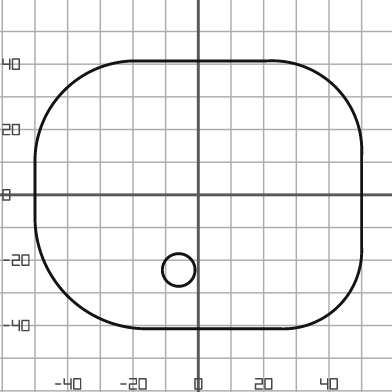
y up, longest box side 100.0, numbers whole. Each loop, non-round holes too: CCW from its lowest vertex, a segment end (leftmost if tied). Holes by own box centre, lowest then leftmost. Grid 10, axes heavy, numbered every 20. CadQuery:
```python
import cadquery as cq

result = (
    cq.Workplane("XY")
    .moveTo(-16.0, -41.0)
    .lineTo(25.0, -41.0)
    .threePointArc((43.0, -34.0), (50.0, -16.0))
    .lineTo(50.0, 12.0)
    .threePointArc((42.0, 33.0), (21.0, 41.0))
    .lineTo(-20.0, 41.0)
    .threePointArc((-41.0, 32.0), (-50.0, 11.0))
    .lineTo(-50.0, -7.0)
    .threePointArc((-40.0, -31.0), (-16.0, -41.0))
    .close()
    .moveTo(-6.0, -23.0)
    .circle(5.0)
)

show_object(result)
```